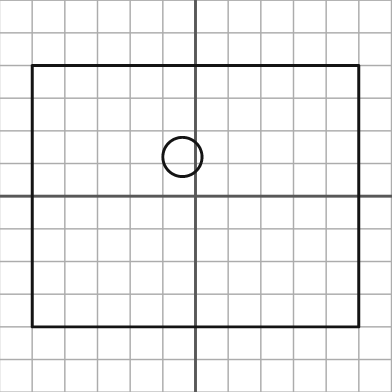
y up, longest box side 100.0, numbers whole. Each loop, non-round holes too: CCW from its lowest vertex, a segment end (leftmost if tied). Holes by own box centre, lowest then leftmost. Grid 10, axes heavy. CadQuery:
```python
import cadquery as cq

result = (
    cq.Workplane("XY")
    .moveTo(-50.0, -40.0)
    .lineTo(50.0, -40.0)
    .lineTo(50.0, 40.0)
    .lineTo(-50.0, 40.0)
    .close()
    .moveTo(-4.0, 12.0)
    .circle(6.0)
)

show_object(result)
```